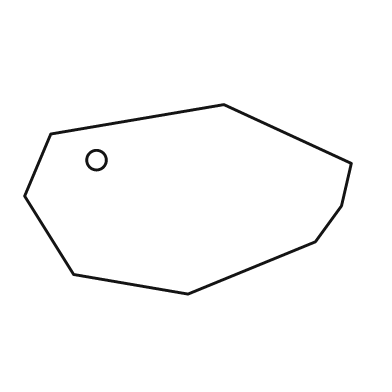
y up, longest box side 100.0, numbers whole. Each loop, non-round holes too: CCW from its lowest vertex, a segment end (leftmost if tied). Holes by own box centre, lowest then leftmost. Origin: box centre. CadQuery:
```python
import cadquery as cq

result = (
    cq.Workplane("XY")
    .moveTo(0.0, -29.0)
    .lineTo(39.0, -13.0)
    .lineTo(47.0, -2.0)
    .lineTo(50.0, 11.0)
    .lineTo(11.0, 29.0)
    .lineTo(-42.0, 20.0)
    .lineTo(-50.0, 1.0)
    .lineTo(-35.0, -23.0)
    .close()
    .moveTo(-28.0, 12.0)
    .circle(3.0)
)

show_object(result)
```